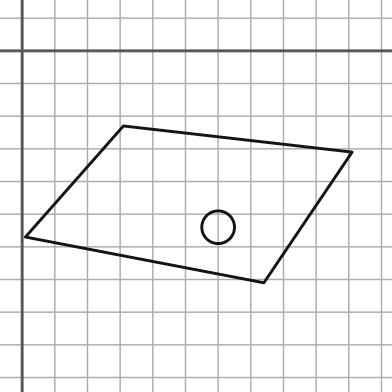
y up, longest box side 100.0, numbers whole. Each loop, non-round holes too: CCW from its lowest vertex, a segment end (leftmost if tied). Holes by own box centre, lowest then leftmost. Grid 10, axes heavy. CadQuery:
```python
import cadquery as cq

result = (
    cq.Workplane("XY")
    .moveTo(74.0, -71.0)
    .lineTo(101.0, -31.0)
    .lineTo(31.0, -23.0)
    .lineTo(1.0, -57.0)
    .close()
    .moveTo(60.0, -54.0)
    .circle(5.0)
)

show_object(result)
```